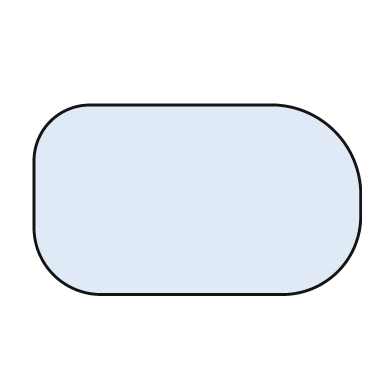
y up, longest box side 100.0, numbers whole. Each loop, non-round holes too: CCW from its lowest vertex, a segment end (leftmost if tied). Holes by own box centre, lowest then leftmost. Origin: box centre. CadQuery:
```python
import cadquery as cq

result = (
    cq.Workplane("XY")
    .moveTo(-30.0, -29.0)
    .lineTo(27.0, -29.0)
    .threePointArc((43.0, -22.0), (50.0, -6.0))
    .lineTo(50.0, 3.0)
    .threePointArc((42.0, 21.0), (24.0, 29.0))
    .lineTo(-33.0, 29.0)
    .threePointArc((-45.0, 24.0), (-50.0, 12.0))
    .lineTo(-50.0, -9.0)
    .threePointArc((-44.0, -23.0), (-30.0, -29.0))
    .close()
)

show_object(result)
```